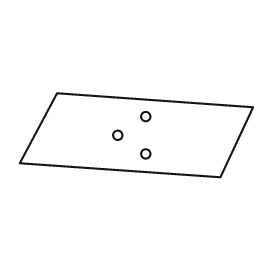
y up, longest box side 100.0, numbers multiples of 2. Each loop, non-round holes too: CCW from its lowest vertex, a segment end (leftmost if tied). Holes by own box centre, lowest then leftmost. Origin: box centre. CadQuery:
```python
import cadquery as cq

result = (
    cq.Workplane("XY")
    .moveTo(36.0, -18.0)
    .lineTo(50.0, 12.0)
    .lineTo(-34.0, 18.0)
    .lineTo(-50.0, -12.0)
    .close()
    .moveTo(4.0, -8.0)
    .circle(2.0)
    .moveTo(-8.0, 0.0)
    .circle(2.0)
    .moveTo(4.0, 8.0)
    .circle(2.0)
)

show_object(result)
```